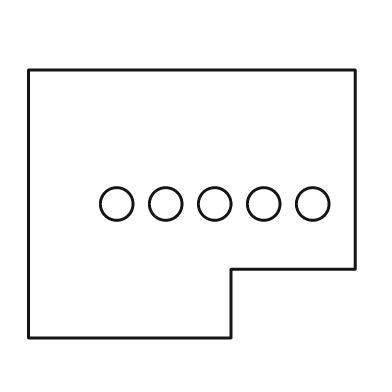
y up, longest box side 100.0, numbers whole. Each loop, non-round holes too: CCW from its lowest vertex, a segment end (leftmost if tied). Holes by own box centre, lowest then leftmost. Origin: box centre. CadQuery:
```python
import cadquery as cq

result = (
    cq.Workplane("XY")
    .moveTo(-50.0, -41.0)
    .lineTo(12.0, -41.0)
    .lineTo(12.0, -20.0)
    .lineTo(50.0, -20.0)
    .lineTo(50.0, 41.0)
    .lineTo(-50.0, 41.0)
    .close()
    .moveTo(-23.0, 0.0)
    .circle(5.0)
    .moveTo(-8.0, 0.0)
    .circle(5.0)
    .moveTo(7.0, 0.0)
    .circle(5.0)
    .moveTo(22.0, 0.0)
    .circle(5.0)
    .moveTo(37.0, 0.0)
    .circle(5.0)
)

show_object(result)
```